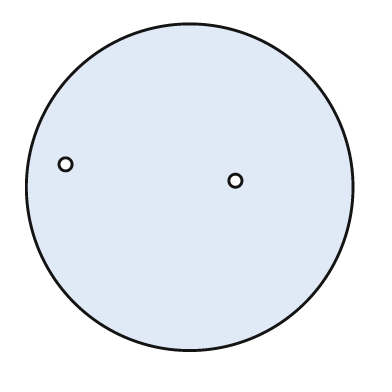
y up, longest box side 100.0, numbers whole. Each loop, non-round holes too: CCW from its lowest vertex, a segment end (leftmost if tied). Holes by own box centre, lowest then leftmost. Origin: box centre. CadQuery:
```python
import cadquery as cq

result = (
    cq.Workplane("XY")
    .moveTo(0.0, 0.0)
    .circle(50.0)
    .moveTo(14.0, 2.0)
    .circle(2.0)
    .moveTo(-38.0, 7.0)
    .circle(2.0)
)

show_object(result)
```